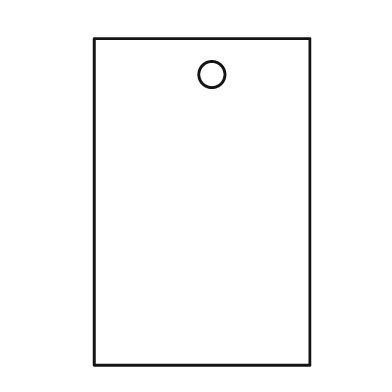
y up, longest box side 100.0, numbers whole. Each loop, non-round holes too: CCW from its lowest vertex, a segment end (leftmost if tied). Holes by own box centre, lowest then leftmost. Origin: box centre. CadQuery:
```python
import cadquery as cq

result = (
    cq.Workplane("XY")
    .moveTo(-33.0, -50.0)
    .lineTo(33.0, -50.0)
    .lineTo(33.0, 50.0)
    .lineTo(-33.0, 50.0)
    .close()
    .moveTo(3.0, 39.0)
    .circle(4.0)
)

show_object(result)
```